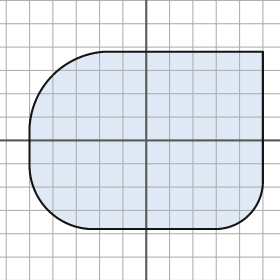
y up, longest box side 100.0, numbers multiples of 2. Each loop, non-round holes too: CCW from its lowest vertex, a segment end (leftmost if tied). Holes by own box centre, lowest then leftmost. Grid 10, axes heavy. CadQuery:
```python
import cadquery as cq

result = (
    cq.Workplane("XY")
    .moveTo(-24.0, -38.0)
    .lineTo(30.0, -38.0)
    .threePointArc((44.0, -32.0), (50.0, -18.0))
    .lineTo(50.0, 38.0)
    .lineTo(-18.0, 38.0)
    .threePointArc((-40.0, 28.0), (-50.0, 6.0))
    .lineTo(-50.0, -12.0)
    .threePointArc((-42.0, -30.0), (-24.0, -38.0))
    .close()
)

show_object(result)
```